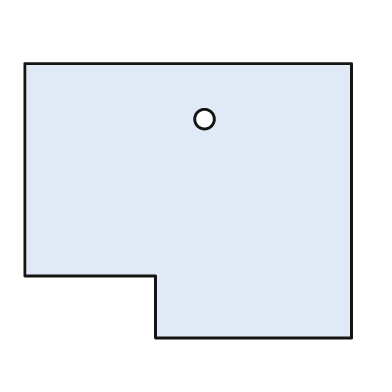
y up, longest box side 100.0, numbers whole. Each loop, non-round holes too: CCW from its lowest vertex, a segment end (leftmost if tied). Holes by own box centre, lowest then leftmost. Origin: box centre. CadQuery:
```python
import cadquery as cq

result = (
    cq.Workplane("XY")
    .moveTo(-10.0, -42.0)
    .lineTo(50.0, -42.0)
    .lineTo(50.0, 42.0)
    .lineTo(-50.0, 42.0)
    .lineTo(-50.0, -23.0)
    .lineTo(-10.0, -23.0)
    .close()
    .moveTo(5.0, 25.0)
    .circle(3.0)
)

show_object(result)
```